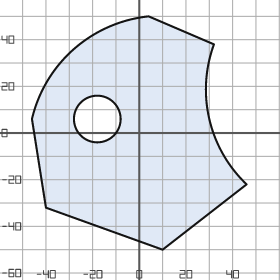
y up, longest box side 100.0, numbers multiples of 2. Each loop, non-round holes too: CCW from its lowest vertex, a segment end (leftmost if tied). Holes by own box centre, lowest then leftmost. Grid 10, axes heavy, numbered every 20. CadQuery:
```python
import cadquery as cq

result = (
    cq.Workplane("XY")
    .moveTo(10.0, -50.0)
    .lineTo(46.0, -22.0)
    .threePointArc((30.0, 6.0), (32.0, 38.0))
    .lineTo(4.0, 50.0)
    .threePointArc((-28.0, 36.0), (-46.0, 6.0))
    .lineTo(-40.0, -32.0)
    .close()
    .moveTo(-18.0, 6.0)
    .circle(10.0)
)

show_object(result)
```